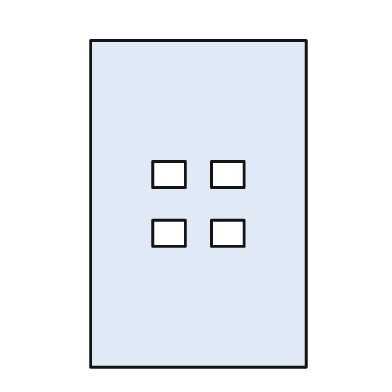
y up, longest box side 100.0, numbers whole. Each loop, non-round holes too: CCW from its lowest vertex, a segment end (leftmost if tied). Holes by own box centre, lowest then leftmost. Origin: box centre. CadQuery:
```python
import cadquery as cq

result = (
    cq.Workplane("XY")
    .moveTo(-33.0, -50.0)
    .lineTo(33.0, -50.0)
    .lineTo(33.0, 50.0)
    .lineTo(-33.0, 50.0)
    .close()
    .moveTo(-14.0, -13.0)
    .lineTo(-4.0, -13.0)
    .lineTo(-4.0, -5.0)
    .lineTo(-14.0, -5.0)
    .close()
    .moveTo(4.0, -13.0)
    .lineTo(14.0, -13.0)
    .lineTo(14.0, -5.0)
    .lineTo(4.0, -5.0)
    .close()
    .moveTo(-14.0, 5.0)
    .lineTo(-4.0, 5.0)
    .lineTo(-4.0, 13.0)
    .lineTo(-14.0, 13.0)
    .close()
    .moveTo(4.0, 5.0)
    .lineTo(14.0, 5.0)
    .lineTo(14.0, 13.0)
    .lineTo(4.0, 13.0)
    .close()
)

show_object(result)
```